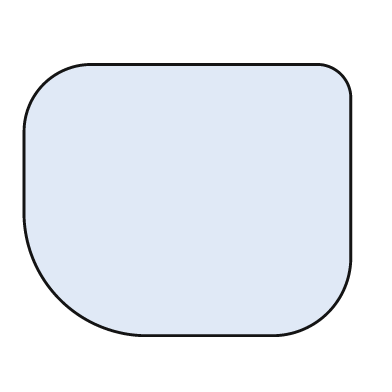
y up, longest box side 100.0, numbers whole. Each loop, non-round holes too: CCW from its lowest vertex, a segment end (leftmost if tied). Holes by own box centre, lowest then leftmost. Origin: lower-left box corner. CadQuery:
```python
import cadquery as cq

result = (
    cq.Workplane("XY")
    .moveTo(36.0, 0.0)
    .lineTo(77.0, 0.0)
    .threePointArc((93.0, 7.0), (100.0, 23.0))
    .lineTo(100.0, 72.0)
    .threePointArc((97.0, 80.0), (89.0, 83.0))
    .lineTo(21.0, 83.0)
    .threePointArc((6.0, 77.0), (0.0, 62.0))
    .lineTo(0.0, 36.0)
    .threePointArc((11.0, 11.0), (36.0, 0.0))
    .close()
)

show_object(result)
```